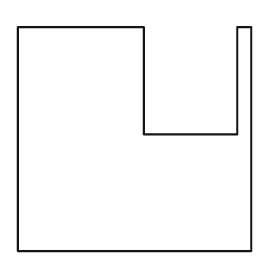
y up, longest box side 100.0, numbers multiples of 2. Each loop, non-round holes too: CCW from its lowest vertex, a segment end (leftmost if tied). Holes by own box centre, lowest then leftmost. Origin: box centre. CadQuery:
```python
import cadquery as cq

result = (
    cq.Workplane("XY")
    .moveTo(-50.0, -48.0)
    .lineTo(50.0, -48.0)
    .lineTo(50.0, 48.0)
    .lineTo(44.0, 48.0)
    .lineTo(44.0, 2.0)
    .lineTo(4.0, 2.0)
    .lineTo(4.0, 48.0)
    .lineTo(-50.0, 48.0)
    .close()
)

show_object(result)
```